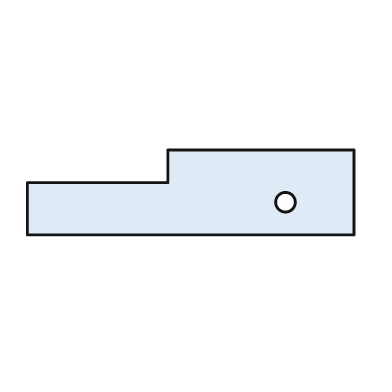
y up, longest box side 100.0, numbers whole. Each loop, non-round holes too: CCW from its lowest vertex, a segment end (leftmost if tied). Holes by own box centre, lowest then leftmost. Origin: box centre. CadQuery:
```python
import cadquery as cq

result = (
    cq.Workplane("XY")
    .moveTo(-50.0, -13.0)
    .lineTo(50.0, -13.0)
    .lineTo(50.0, 13.0)
    .lineTo(-7.0, 13.0)
    .lineTo(-7.0, 3.0)
    .lineTo(-50.0, 3.0)
    .close()
    .moveTo(29.0, -3.0)
    .circle(3.0)
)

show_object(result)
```